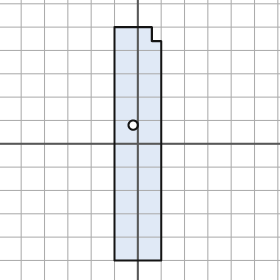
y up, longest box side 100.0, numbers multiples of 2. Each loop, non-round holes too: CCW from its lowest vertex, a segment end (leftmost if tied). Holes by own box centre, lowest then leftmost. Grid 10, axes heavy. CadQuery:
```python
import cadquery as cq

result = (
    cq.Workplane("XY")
    .moveTo(-10.0, -50.0)
    .lineTo(10.0, -50.0)
    .lineTo(10.0, 44.0)
    .lineTo(6.0, 44.0)
    .lineTo(6.0, 50.0)
    .lineTo(-10.0, 50.0)
    .close()
    .moveTo(-2.0, 8.0)
    .circle(2.0)
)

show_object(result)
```